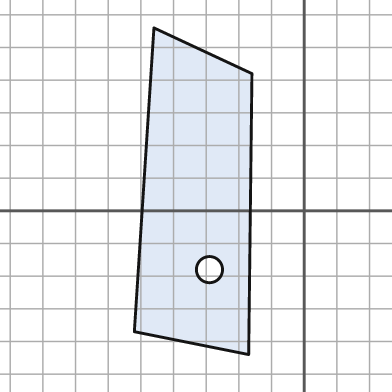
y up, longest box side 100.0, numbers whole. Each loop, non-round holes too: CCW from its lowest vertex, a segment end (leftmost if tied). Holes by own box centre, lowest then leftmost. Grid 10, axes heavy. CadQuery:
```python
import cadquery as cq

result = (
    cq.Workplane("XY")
    .moveTo(-17.0, -44.0)
    .lineTo(-16.0, 42.0)
    .lineTo(-46.0, 56.0)
    .lineTo(-52.0, -37.0)
    .close()
    .moveTo(-29.0, -18.0)
    .circle(4.0)
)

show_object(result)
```